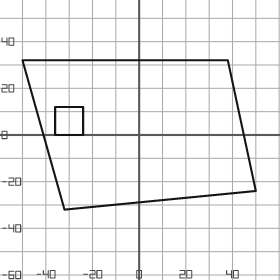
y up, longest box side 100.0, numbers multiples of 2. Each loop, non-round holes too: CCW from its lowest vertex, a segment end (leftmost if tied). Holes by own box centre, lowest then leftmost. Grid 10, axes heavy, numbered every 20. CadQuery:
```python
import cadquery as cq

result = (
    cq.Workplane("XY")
    .moveTo(-32.0, -32.0)
    .lineTo(50.0, -24.0)
    .lineTo(38.0, 32.0)
    .lineTo(-50.0, 32.0)
    .close()
    .moveTo(-36.0, 0.0)
    .lineTo(-24.0, 0.0)
    .lineTo(-24.0, 12.0)
    .lineTo(-36.0, 12.0)
    .close()
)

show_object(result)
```